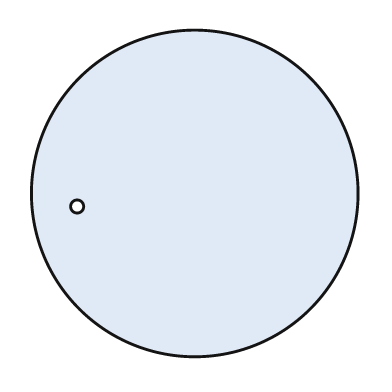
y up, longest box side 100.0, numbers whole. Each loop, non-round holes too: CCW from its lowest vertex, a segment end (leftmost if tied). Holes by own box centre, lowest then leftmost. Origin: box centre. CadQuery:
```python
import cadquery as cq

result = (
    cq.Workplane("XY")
    .moveTo(0.0, 0.0)
    .circle(50.0)
    .moveTo(-36.0, -4.0)
    .circle(2.0)
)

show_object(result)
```